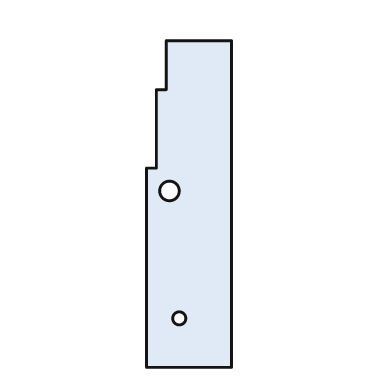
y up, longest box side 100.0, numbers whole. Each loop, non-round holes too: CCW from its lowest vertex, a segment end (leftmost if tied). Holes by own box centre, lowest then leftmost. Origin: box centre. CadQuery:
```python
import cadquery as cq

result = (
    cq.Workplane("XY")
    .moveTo(-13.0, -50.0)
    .lineTo(13.0, -50.0)
    .lineTo(13.0, 50.0)
    .lineTo(-7.0, 50.0)
    .lineTo(-7.0, 35.0)
    .lineTo(-10.0, 35.0)
    .lineTo(-10.0, 11.0)
    .lineTo(-13.0, 11.0)
    .close()
    .moveTo(-3.0, -35.0)
    .circle(2.0)
    .moveTo(-6.0, 4.0)
    .circle(3.0)
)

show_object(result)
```